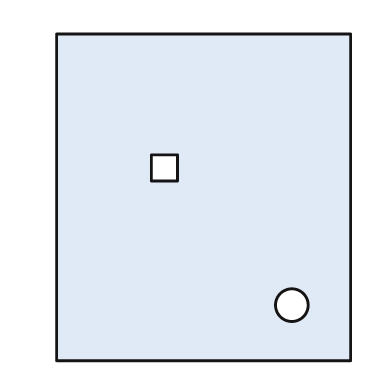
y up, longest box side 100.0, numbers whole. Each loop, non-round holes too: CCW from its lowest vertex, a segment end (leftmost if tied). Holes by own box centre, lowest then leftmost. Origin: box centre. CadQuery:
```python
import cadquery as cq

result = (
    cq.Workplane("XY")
    .moveTo(-45.0, -50.0)
    .lineTo(45.0, -50.0)
    .lineTo(45.0, 50.0)
    .lineTo(-45.0, 50.0)
    .close()
    .moveTo(27.0, -33.0)
    .circle(5.0)
    .moveTo(-16.0, 5.0)
    .lineTo(-8.0, 5.0)
    .lineTo(-8.0, 13.0)
    .lineTo(-16.0, 13.0)
    .close()
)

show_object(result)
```